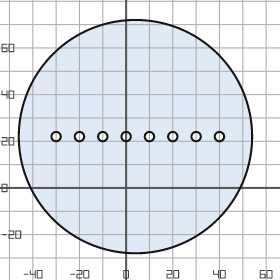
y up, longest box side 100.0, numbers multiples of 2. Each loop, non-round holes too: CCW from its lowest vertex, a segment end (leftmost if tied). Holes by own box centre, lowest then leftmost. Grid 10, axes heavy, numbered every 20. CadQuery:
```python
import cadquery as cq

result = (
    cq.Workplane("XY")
    .moveTo(4.0, 22.0)
    .circle(50.0)
    .moveTo(-30.0, 22.0)
    .circle(2.0)
    .moveTo(-20.0, 22.0)
    .circle(2.0)
    .moveTo(-10.0, 22.0)
    .circle(2.0)
    .moveTo(0.0, 22.0)
    .circle(2.0)
    .moveTo(10.0, 22.0)
    .circle(2.0)
    .moveTo(20.0, 22.0)
    .circle(2.0)
    .moveTo(30.0, 22.0)
    .circle(2.0)
    .moveTo(40.0, 22.0)
    .circle(2.0)
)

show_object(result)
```